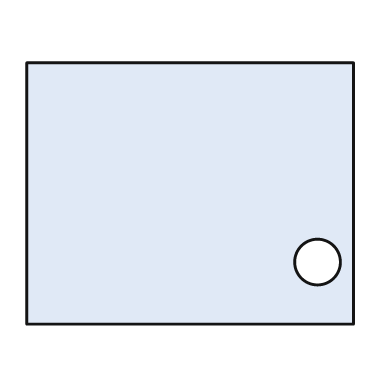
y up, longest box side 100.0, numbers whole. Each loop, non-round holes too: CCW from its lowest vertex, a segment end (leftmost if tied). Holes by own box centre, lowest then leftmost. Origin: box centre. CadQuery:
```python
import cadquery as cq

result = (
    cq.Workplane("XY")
    .moveTo(-50.0, -40.0)
    .lineTo(50.0, -40.0)
    .lineTo(50.0, 40.0)
    .lineTo(-50.0, 40.0)
    .close()
    .moveTo(39.0, -21.0)
    .circle(7.0)
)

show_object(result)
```